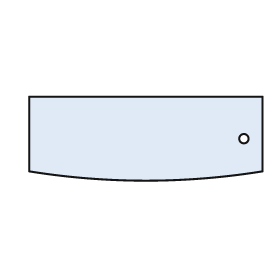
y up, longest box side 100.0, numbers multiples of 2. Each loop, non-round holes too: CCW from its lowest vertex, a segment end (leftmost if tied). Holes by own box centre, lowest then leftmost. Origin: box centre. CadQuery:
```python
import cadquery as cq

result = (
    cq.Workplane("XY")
    .moveTo(-50.0, -14.0)
    .threePointArc((0.0, -18.0), (50.0, -14.0))
    .lineTo(50.0, 18.0)
    .lineTo(-50.0, 18.0)
    .close()
    .moveTo(42.0, 0.0)
    .circle(2.0)
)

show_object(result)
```